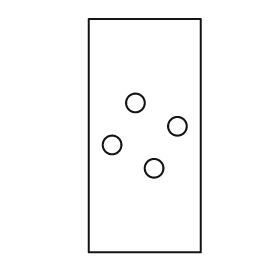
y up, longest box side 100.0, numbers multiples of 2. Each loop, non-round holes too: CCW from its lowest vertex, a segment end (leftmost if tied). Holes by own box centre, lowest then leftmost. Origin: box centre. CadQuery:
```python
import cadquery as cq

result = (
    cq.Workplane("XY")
    .moveTo(-24.0, -50.0)
    .lineTo(24.0, -50.0)
    .lineTo(24.0, 50.0)
    .lineTo(-24.0, 50.0)
    .close()
    .moveTo(4.0, -14.0)
    .circle(4.0)
    .moveTo(-14.0, -4.0)
    .circle(4.0)
    .moveTo(14.0, 4.0)
    .circle(4.0)
    .moveTo(-4.0, 14.0)
    .circle(4.0)
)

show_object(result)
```